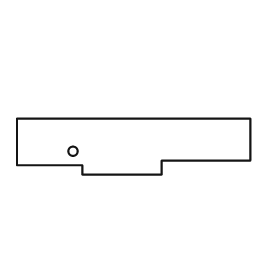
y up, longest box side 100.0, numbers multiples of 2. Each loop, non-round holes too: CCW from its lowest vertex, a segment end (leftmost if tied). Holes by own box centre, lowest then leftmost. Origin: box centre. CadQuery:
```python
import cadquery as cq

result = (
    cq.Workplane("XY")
    .moveTo(-22.0, -12.0)
    .lineTo(12.0, -12.0)
    .lineTo(12.0, -6.0)
    .lineTo(50.0, -6.0)
    .lineTo(50.0, 12.0)
    .lineTo(-50.0, 12.0)
    .lineTo(-50.0, -8.0)
    .lineTo(-22.0, -8.0)
    .close()
    .moveTo(-26.0, -2.0)
    .circle(2.0)
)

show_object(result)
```